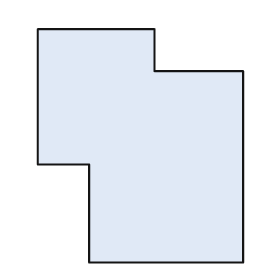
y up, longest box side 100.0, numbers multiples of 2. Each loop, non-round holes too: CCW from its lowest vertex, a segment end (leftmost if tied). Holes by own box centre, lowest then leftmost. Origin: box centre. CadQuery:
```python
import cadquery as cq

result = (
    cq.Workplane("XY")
    .moveTo(-22.0, -50.0)
    .lineTo(44.0, -50.0)
    .lineTo(44.0, 32.0)
    .lineTo(6.0, 32.0)
    .lineTo(6.0, 50.0)
    .lineTo(-44.0, 50.0)
    .lineTo(-44.0, -8.0)
    .lineTo(-22.0, -8.0)
    .close()
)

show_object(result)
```